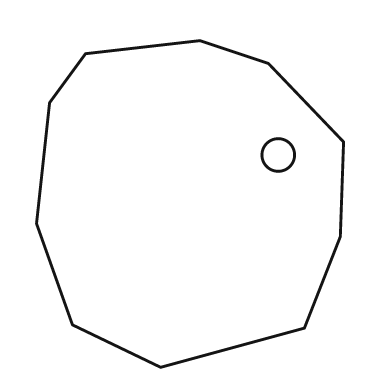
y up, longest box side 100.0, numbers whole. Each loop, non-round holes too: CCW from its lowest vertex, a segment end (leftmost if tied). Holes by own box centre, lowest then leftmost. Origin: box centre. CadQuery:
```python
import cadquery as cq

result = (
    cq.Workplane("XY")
    .moveTo(-9.0, -50.0)
    .lineTo(35.0, -38.0)
    .lineTo(46.0, -10.0)
    .lineTo(47.0, 19.0)
    .lineTo(24.0, 43.0)
    .lineTo(3.0, 50.0)
    .lineTo(-32.0, 46.0)
    .lineTo(-43.0, 31.0)
    .lineTo(-47.0, -6.0)
    .lineTo(-36.0, -37.0)
    .close()
    .moveTo(27.0, 15.0)
    .circle(5.0)
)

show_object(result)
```